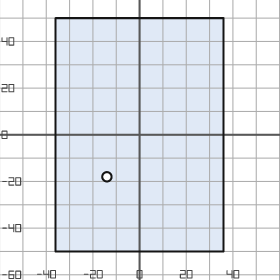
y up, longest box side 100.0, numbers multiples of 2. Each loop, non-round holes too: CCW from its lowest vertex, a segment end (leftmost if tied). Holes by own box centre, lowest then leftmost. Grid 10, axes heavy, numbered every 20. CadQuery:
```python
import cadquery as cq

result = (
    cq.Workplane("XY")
    .moveTo(-36.0, -50.0)
    .lineTo(36.0, -50.0)
    .lineTo(36.0, 50.0)
    .lineTo(-36.0, 50.0)
    .close()
    .moveTo(-14.0, -18.0)
    .circle(2.0)
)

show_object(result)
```